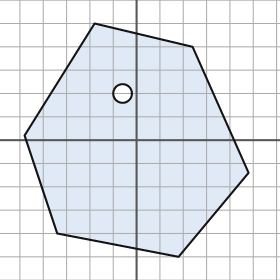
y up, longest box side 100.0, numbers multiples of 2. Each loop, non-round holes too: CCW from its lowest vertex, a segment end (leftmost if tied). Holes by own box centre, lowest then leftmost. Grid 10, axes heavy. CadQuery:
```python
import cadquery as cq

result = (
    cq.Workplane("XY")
    .moveTo(18.0, -50.0)
    .lineTo(48.0, -14.0)
    .lineTo(24.0, 40.0)
    .lineTo(-18.0, 50.0)
    .lineTo(-48.0, 2.0)
    .lineTo(-34.0, -40.0)
    .close()
    .moveTo(-6.0, 20.0)
    .circle(4.0)
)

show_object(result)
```